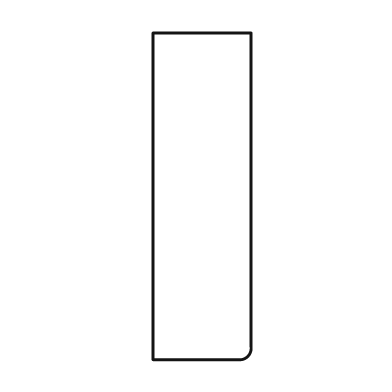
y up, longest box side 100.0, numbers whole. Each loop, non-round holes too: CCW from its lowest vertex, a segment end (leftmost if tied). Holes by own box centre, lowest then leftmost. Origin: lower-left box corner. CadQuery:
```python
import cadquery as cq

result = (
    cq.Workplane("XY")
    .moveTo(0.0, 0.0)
    .lineTo(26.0, 0.0)
    .threePointArc((29.0, 1.0), (30.0, 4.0))
    .lineTo(30.0, 100.0)
    .lineTo(0.0, 100.0)
    .close()
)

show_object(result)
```